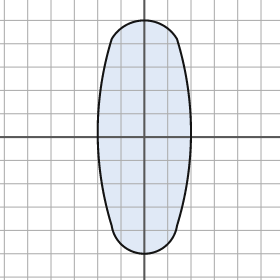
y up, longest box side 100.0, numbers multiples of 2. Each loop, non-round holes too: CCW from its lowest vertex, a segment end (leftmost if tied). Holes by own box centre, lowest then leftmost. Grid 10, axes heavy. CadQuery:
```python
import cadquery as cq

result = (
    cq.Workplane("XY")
    .moveTo(-14.0, -38.0)
    .threePointArc((0.0, -50.0), (14.0, -38.0))
    .threePointArc((20.0, 2.0), (14.0, 42.0))
    .threePointArc((0.0, 50.0), (-14.0, 42.0))
    .threePointArc((-20.0, 2.0), (-14.0, -38.0))
    .close()
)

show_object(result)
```